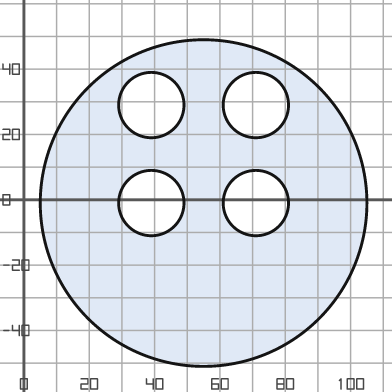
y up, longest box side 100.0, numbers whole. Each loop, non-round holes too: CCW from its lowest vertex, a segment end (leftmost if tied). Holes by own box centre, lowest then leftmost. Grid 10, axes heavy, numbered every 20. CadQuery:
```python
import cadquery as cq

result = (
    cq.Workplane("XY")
    .moveTo(55.0, -1.0)
    .circle(50.0)
    .moveTo(39.0, -1.0)
    .circle(10.0)
    .moveTo(71.0, -1.0)
    .circle(10.0)
    .moveTo(39.0, 29.0)
    .circle(10.0)
    .moveTo(71.0, 29.0)
    .circle(10.0)
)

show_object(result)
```